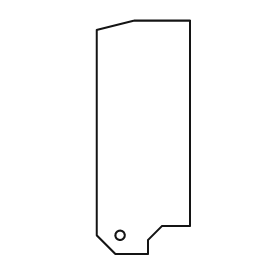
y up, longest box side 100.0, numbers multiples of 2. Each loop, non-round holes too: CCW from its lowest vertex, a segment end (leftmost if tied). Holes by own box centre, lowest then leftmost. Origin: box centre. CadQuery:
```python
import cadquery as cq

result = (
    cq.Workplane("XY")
    .moveTo(-12.0, -50.0)
    .lineTo(2.0, -50.0)
    .lineTo(2.0, -44.0)
    .lineTo(8.0, -38.0)
    .lineTo(20.0, -38.0)
    .lineTo(20.0, 50.0)
    .lineTo(-4.0, 50.0)
    .lineTo(-20.0, 46.0)
    .lineTo(-20.0, -42.0)
    .close()
    .moveTo(-10.0, -42.0)
    .circle(2.0)
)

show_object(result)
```